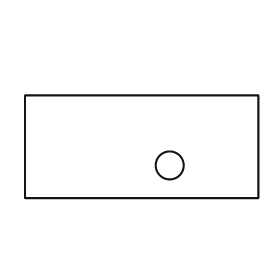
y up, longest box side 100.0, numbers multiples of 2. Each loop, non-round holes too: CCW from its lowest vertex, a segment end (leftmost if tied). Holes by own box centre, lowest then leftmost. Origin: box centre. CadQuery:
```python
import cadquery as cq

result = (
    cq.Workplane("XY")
    .moveTo(-50.0, -22.0)
    .lineTo(50.0, -22.0)
    .lineTo(50.0, 22.0)
    .lineTo(-50.0, 22.0)
    .close()
    .moveTo(12.0, -8.0)
    .circle(6.0)
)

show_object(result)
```